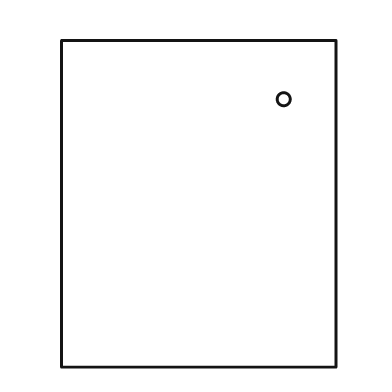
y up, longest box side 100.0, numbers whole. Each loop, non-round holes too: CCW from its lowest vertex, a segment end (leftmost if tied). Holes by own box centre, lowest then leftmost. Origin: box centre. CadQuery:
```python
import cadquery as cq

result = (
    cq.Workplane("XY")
    .moveTo(-42.0, -50.0)
    .lineTo(42.0, -50.0)
    .lineTo(42.0, 50.0)
    .lineTo(-42.0, 50.0)
    .close()
    .moveTo(26.0, 32.0)
    .circle(2.0)
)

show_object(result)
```